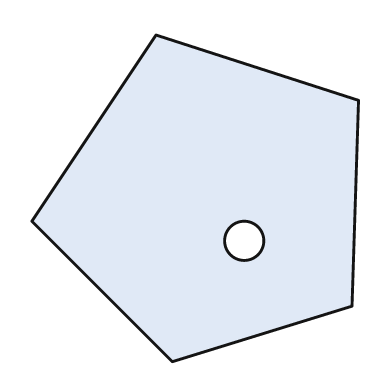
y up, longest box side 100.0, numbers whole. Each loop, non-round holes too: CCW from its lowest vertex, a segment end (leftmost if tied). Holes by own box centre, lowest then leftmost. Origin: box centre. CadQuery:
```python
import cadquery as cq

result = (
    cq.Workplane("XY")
    .moveTo(-7.0, -50.0)
    .lineTo(48.0, -33.0)
    .lineTo(50.0, 30.0)
    .lineTo(-12.0, 50.0)
    .lineTo(-50.0, -7.0)
    .close()
    .moveTo(15.0, -13.0)
    .circle(6.0)
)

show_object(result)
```